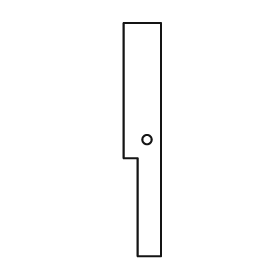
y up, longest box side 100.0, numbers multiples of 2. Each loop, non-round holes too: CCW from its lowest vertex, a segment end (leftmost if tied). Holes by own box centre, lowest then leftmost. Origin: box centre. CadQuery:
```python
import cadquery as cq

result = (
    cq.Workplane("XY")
    .moveTo(-2.0, -50.0)
    .lineTo(8.0, -50.0)
    .lineTo(8.0, 50.0)
    .lineTo(-8.0, 50.0)
    .lineTo(-8.0, -8.0)
    .lineTo(-2.0, -8.0)
    .close()
    .moveTo(2.0, 0.0)
    .circle(2.0)
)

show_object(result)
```